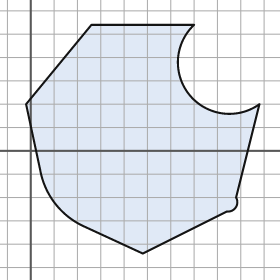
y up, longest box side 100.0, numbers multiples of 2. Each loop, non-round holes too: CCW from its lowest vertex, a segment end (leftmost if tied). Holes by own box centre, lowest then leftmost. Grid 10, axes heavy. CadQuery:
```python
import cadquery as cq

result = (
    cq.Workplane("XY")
    .moveTo(48.0, -44.0)
    .lineTo(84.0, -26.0)
    .threePointArc((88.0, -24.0), (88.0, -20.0))
    .lineTo(98.0, 20.0)
    .threePointArc((68.0, 24.0), (70.0, 54.0))
    .lineTo(26.0, 54.0)
    .lineTo(-2.0, 20.0)
    .lineTo(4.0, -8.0)
    .threePointArc((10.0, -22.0), (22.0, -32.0))
    .close()
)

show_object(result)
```